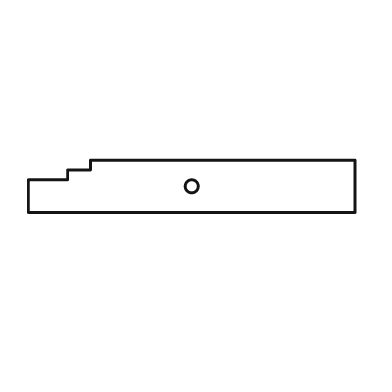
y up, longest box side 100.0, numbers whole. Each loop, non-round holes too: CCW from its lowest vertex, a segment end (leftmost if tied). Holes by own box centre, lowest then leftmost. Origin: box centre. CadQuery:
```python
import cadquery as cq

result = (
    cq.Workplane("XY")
    .moveTo(-50.0, -8.0)
    .lineTo(50.0, -8.0)
    .lineTo(50.0, 8.0)
    .lineTo(-31.0, 8.0)
    .lineTo(-31.0, 5.0)
    .lineTo(-38.0, 5.0)
    .lineTo(-38.0, 2.0)
    .lineTo(-50.0, 2.0)
    .close()
    .moveTo(0.0, 0.0)
    .circle(2.0)
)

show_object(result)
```